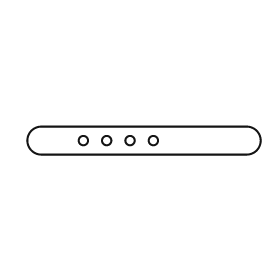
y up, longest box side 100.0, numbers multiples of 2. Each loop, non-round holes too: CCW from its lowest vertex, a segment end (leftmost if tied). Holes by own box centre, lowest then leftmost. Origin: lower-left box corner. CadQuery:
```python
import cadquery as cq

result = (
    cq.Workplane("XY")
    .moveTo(6.0, 0.0)
    .lineTo(94.0, 0.0)
    .threePointArc((100.0, 6.0), (94.0, 12.0))
    .lineTo(6.0, 12.0)
    .threePointArc((0.0, 6.0), (6.0, 0.0))
    .close()
    .moveTo(24.0, 6.0)
    .circle(2.0)
    .moveTo(34.0, 6.0)
    .circle(2.0)
    .moveTo(44.0, 6.0)
    .circle(2.0)
    .moveTo(54.0, 6.0)
    .circle(2.0)
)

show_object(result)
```